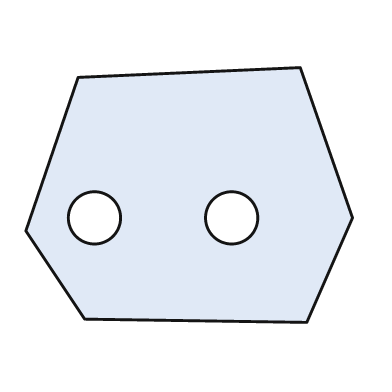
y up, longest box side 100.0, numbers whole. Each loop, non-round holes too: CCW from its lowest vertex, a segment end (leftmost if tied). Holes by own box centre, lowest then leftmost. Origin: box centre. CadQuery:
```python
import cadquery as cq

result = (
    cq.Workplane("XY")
    .moveTo(36.0, -39.0)
    .lineTo(50.0, -7.0)
    .lineTo(34.0, 39.0)
    .lineTo(-34.0, 36.0)
    .lineTo(-50.0, -11.0)
    .lineTo(-32.0, -38.0)
    .close()
    .moveTo(-29.0, -7.0)
    .circle(8.0)
    .moveTo(13.0, -7.0)
    .circle(8.0)
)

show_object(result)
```